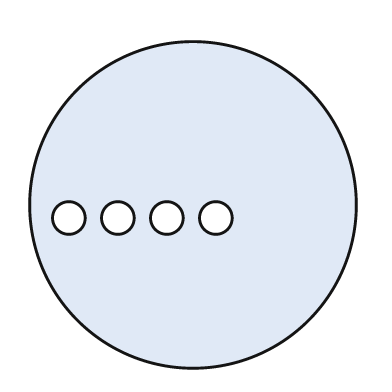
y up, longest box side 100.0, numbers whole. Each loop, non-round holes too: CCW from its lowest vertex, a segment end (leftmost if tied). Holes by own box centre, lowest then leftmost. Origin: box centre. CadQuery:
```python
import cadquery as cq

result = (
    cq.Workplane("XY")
    .moveTo(0.0, 0.0)
    .circle(50.0)
    .moveTo(-38.0, -4.0)
    .circle(5.0)
    .moveTo(-23.0, -4.0)
    .circle(5.0)
    .moveTo(-8.0, -4.0)
    .circle(5.0)
    .moveTo(7.0, -4.0)
    .circle(5.0)
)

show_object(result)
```